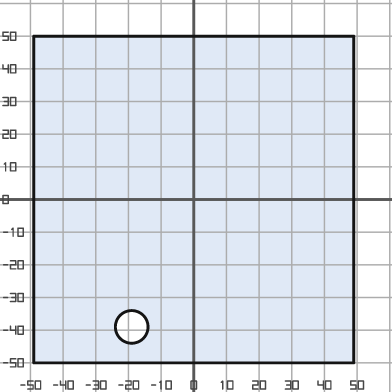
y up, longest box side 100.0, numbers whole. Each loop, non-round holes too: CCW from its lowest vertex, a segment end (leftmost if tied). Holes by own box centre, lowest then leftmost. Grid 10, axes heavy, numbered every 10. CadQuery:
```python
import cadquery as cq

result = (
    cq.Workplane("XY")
    .moveTo(-49.0, -50.0)
    .lineTo(49.0, -50.0)
    .lineTo(49.0, 50.0)
    .lineTo(-49.0, 50.0)
    .close()
    .moveTo(-19.0, -39.0)
    .circle(5.0)
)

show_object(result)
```